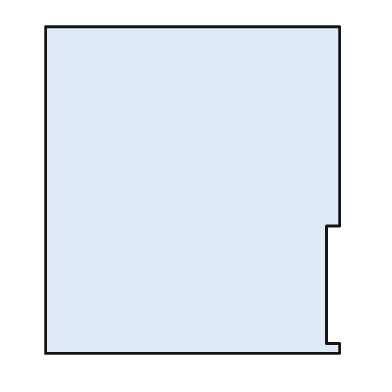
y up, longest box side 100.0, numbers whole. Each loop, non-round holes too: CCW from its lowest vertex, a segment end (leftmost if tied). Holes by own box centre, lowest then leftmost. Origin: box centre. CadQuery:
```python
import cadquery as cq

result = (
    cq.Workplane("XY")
    .moveTo(-45.0, -50.0)
    .lineTo(45.0, -50.0)
    .lineTo(45.0, -47.0)
    .lineTo(41.0, -47.0)
    .lineTo(41.0, -11.0)
    .lineTo(45.0, -11.0)
    .lineTo(45.0, 50.0)
    .lineTo(-45.0, 50.0)
    .close()
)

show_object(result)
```